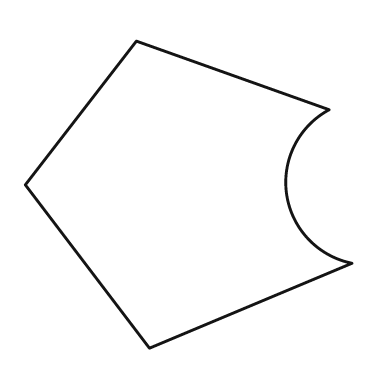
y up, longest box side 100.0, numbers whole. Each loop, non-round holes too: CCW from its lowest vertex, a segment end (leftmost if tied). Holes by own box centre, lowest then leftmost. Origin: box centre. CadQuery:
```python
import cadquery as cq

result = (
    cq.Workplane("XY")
    .moveTo(-12.0, -47.0)
    .lineTo(50.0, -21.0)
    .threePointArc((30.0, 0.0), (43.0, 26.0))
    .lineTo(-16.0, 47.0)
    .lineTo(-50.0, 3.0)
    .close()
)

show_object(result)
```